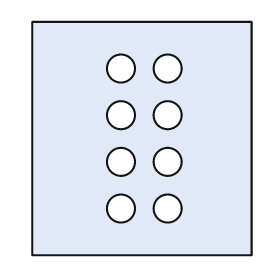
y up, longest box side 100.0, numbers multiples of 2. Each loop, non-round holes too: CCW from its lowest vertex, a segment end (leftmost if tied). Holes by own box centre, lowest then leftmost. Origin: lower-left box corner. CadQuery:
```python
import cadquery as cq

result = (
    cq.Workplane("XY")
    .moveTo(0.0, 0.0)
    .lineTo(94.0, 0.0)
    .lineTo(94.0, 100.0)
    .lineTo(0.0, 100.0)
    .close()
    .moveTo(38.0, 20.0)
    .circle(6.0)
    .moveTo(58.0, 20.0)
    .circle(6.0)
    .moveTo(38.0, 40.0)
    .circle(6.0)
    .moveTo(58.0, 40.0)
    .circle(6.0)
    .moveTo(38.0, 60.0)
    .circle(6.0)
    .moveTo(58.0, 60.0)
    .circle(6.0)
    .moveTo(38.0, 80.0)
    .circle(6.0)
    .moveTo(58.0, 80.0)
    .circle(6.0)
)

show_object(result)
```